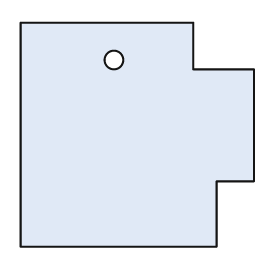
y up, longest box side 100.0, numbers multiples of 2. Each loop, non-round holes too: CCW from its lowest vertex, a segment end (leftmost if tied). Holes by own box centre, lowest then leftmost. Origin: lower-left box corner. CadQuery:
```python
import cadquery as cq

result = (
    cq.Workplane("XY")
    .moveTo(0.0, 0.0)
    .lineTo(84.0, 0.0)
    .lineTo(84.0, 28.0)
    .lineTo(100.0, 28.0)
    .lineTo(100.0, 76.0)
    .lineTo(74.0, 76.0)
    .lineTo(74.0, 96.0)
    .lineTo(0.0, 96.0)
    .close()
    .moveTo(40.0, 80.0)
    .circle(4.0)
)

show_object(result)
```